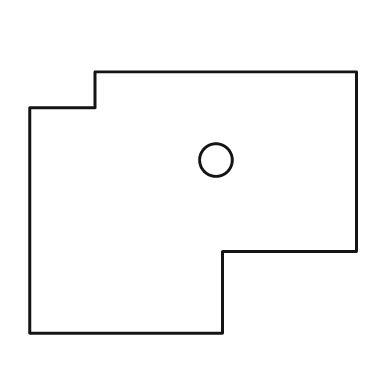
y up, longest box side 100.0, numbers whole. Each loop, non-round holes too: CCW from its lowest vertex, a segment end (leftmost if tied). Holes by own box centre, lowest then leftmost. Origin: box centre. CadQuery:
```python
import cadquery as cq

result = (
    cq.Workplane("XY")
    .moveTo(-50.0, -40.0)
    .lineTo(9.0, -40.0)
    .lineTo(9.0, -15.0)
    .lineTo(50.0, -15.0)
    .lineTo(50.0, 40.0)
    .lineTo(-30.0, 40.0)
    .lineTo(-30.0, 29.0)
    .lineTo(-50.0, 29.0)
    .close()
    .moveTo(7.0, 13.0)
    .circle(5.0)
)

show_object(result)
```